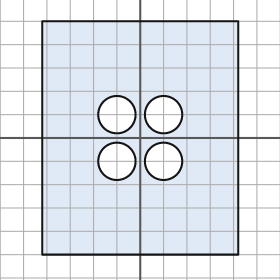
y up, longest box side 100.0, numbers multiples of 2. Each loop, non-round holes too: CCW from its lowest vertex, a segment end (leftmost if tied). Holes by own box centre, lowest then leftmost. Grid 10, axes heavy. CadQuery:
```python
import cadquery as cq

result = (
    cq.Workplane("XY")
    .moveTo(-42.0, -50.0)
    .lineTo(42.0, -50.0)
    .lineTo(42.0, 50.0)
    .lineTo(-42.0, 50.0)
    .close()
    .moveTo(-10.0, -10.0)
    .circle(8.0)
    .moveTo(10.0, -10.0)
    .circle(8.0)
    .moveTo(-10.0, 10.0)
    .circle(8.0)
    .moveTo(10.0, 10.0)
    .circle(8.0)
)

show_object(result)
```